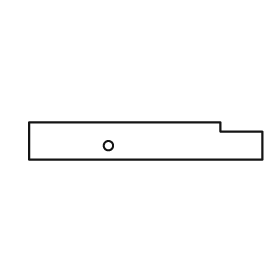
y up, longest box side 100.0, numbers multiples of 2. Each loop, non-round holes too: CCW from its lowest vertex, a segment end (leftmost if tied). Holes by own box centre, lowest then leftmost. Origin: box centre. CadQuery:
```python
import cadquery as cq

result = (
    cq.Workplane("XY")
    .moveTo(-50.0, -8.0)
    .lineTo(50.0, -8.0)
    .lineTo(50.0, 4.0)
    .lineTo(32.0, 4.0)
    .lineTo(32.0, 8.0)
    .lineTo(-50.0, 8.0)
    .close()
    .moveTo(-16.0, -2.0)
    .circle(2.0)
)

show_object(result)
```